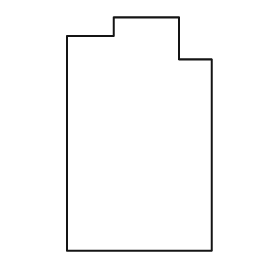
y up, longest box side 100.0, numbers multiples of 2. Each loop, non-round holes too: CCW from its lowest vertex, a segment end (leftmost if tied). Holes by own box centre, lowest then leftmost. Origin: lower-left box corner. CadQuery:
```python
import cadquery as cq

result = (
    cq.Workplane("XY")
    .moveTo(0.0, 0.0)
    .lineTo(62.0, 0.0)
    .lineTo(62.0, 82.0)
    .lineTo(48.0, 82.0)
    .lineTo(48.0, 100.0)
    .lineTo(20.0, 100.0)
    .lineTo(20.0, 92.0)
    .lineTo(0.0, 92.0)
    .close()
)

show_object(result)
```